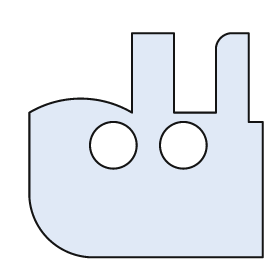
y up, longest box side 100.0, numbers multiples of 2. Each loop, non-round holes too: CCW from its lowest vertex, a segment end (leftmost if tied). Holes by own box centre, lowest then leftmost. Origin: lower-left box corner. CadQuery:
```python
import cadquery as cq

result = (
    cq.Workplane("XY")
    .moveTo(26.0, 0.0)
    .lineTo(100.0, 0.0)
    .lineTo(100.0, 58.0)
    .lineTo(94.0, 58.0)
    .lineTo(94.0, 96.0)
    .lineTo(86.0, 96.0)
    .threePointArc((82.0, 94.0), (80.0, 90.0))
    .lineTo(80.0, 62.0)
    .lineTo(62.0, 62.0)
    .lineTo(62.0, 96.0)
    .lineTo(44.0, 96.0)
    .lineTo(44.0, 62.0)
    .threePointArc((22.0, 68.0), (0.0, 62.0))
    .lineTo(0.0, 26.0)
    .threePointArc((8.0, 8.0), (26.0, 0.0))
    .close()
    .moveTo(36.0, 48.0)
    .circle(10.0)
    .moveTo(66.0, 48.0)
    .circle(10.0)
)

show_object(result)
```